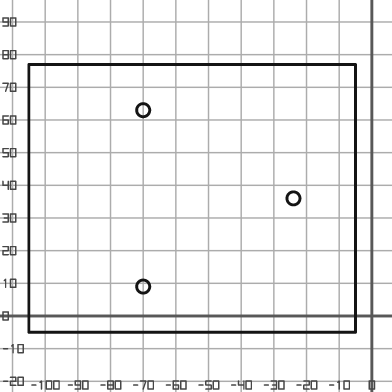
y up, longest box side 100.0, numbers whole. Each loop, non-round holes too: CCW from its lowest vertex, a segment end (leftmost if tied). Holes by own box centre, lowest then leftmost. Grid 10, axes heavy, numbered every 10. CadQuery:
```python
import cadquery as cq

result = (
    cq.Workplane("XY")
    .moveTo(-105.0, -5.0)
    .lineTo(-5.0, -5.0)
    .lineTo(-5.0, 77.0)
    .lineTo(-105.0, 77.0)
    .close()
    .moveTo(-70.0, 9.0)
    .circle(2.0)
    .moveTo(-24.0, 36.0)
    .circle(2.0)
    .moveTo(-70.0, 63.0)
    .circle(2.0)
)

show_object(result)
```